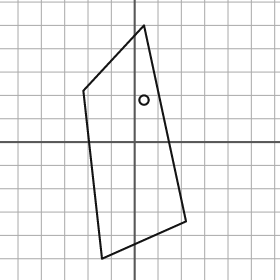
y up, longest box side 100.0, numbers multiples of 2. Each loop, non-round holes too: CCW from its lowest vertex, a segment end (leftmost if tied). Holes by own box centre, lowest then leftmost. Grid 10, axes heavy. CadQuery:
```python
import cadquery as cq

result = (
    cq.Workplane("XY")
    .moveTo(-14.0, -50.0)
    .lineTo(22.0, -34.0)
    .lineTo(4.0, 50.0)
    .lineTo(-22.0, 22.0)
    .close()
    .moveTo(4.0, 18.0)
    .circle(2.0)
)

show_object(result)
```